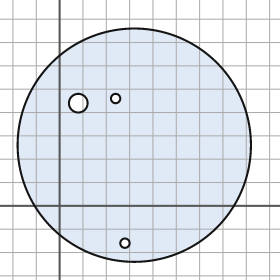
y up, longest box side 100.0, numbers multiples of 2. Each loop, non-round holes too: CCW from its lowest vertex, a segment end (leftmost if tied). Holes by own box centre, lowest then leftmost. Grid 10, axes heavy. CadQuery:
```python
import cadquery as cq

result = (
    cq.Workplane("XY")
    .moveTo(32.0, 26.0)
    .circle(50.0)
    .moveTo(28.0, -16.0)
    .circle(2.0)
    .moveTo(8.0, 44.0)
    .circle(4.0)
    .moveTo(24.0, 46.0)
    .circle(2.0)
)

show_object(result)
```